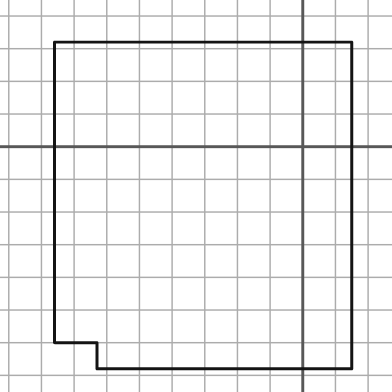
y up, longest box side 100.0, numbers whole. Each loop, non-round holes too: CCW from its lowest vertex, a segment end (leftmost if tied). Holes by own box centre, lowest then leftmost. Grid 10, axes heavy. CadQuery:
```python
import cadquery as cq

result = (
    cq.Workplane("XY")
    .moveTo(-63.0, -68.0)
    .lineTo(15.0, -68.0)
    .lineTo(15.0, 32.0)
    .lineTo(-76.0, 32.0)
    .lineTo(-76.0, -60.0)
    .lineTo(-63.0, -60.0)
    .close()
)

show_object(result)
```